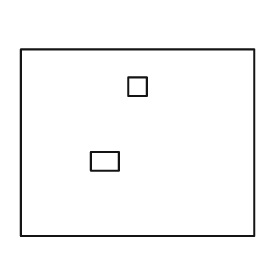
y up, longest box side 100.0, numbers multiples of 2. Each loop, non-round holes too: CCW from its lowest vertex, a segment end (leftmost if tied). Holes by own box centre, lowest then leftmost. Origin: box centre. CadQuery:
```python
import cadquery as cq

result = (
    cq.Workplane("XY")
    .moveTo(-50.0, -40.0)
    .lineTo(50.0, -40.0)
    .lineTo(50.0, 40.0)
    .lineTo(-50.0, 40.0)
    .close()
    .moveTo(-20.0, -12.0)
    .lineTo(-8.0, -12.0)
    .lineTo(-8.0, -4.0)
    .lineTo(-20.0, -4.0)
    .close()
    .moveTo(-4.0, 20.0)
    .lineTo(4.0, 20.0)
    .lineTo(4.0, 28.0)
    .lineTo(-4.0, 28.0)
    .close()
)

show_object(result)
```